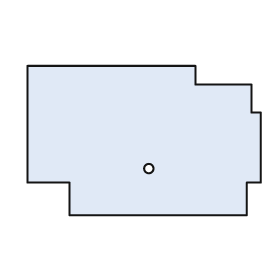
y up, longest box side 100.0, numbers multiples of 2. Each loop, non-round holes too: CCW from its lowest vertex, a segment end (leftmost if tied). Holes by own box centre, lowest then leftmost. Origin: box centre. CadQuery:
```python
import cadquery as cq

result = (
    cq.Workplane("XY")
    .moveTo(-32.0, -32.0)
    .lineTo(44.0, -32.0)
    .lineTo(44.0, -18.0)
    .lineTo(50.0, -18.0)
    .lineTo(50.0, 12.0)
    .lineTo(46.0, 12.0)
    .lineTo(46.0, 24.0)
    .lineTo(22.0, 24.0)
    .lineTo(22.0, 32.0)
    .lineTo(-50.0, 32.0)
    .lineTo(-50.0, -18.0)
    .lineTo(-32.0, -18.0)
    .close()
    .moveTo(2.0, -12.0)
    .circle(2.0)
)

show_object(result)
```